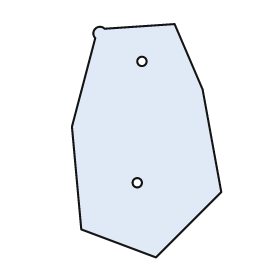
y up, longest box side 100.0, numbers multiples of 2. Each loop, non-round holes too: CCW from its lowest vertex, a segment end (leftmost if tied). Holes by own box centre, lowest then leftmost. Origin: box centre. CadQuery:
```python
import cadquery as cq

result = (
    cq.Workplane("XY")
    .moveTo(4.0, -50.0)
    .lineTo(32.0, -22.0)
    .lineTo(24.0, 22.0)
    .lineTo(12.0, 50.0)
    .lineTo(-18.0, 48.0)
    .threePointArc((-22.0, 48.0), (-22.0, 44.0))
    .lineTo(-32.0, 6.0)
    .lineTo(-28.0, -38.0)
    .close()
    .moveTo(-4.0, -18.0)
    .circle(2.0)
    .moveTo(-2.0, 34.0)
    .circle(2.0)
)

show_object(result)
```